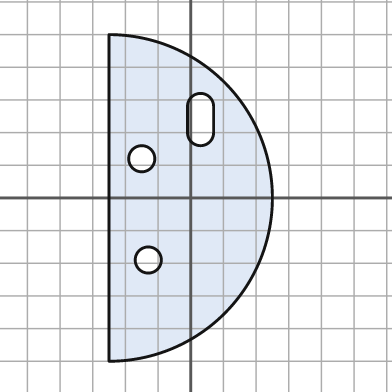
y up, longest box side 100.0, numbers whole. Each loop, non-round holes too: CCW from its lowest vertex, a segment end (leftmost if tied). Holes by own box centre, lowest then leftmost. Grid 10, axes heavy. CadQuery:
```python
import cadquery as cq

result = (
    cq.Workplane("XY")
    .moveTo(-25.0, -50.0)
    .threePointArc((25.0, 0.0), (-25.0, 50.0))
    .close()
    .moveTo(-13.0, -19.0)
    .circle(4.0)
    .moveTo(-15.0, 12.0)
    .circle(4.0)
    .moveTo(-1.0, 20.0)
    .threePointArc((3.0, 16.0), (7.0, 20.0))
    .lineTo(7.0, 28.0)
    .threePointArc((3.0, 32.0), (-1.0, 28.0))
    .close()
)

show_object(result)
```